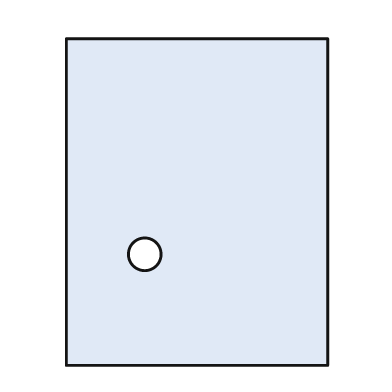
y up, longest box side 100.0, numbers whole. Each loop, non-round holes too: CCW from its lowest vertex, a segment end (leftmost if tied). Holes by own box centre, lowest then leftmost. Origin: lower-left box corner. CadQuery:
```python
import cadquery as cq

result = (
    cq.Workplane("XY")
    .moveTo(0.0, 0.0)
    .lineTo(80.0, 0.0)
    .lineTo(80.0, 100.0)
    .lineTo(0.0, 100.0)
    .close()
    .moveTo(24.0, 34.0)
    .circle(5.0)
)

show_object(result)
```